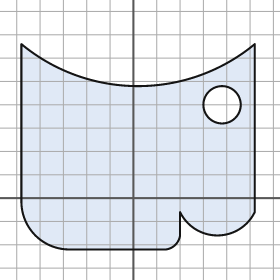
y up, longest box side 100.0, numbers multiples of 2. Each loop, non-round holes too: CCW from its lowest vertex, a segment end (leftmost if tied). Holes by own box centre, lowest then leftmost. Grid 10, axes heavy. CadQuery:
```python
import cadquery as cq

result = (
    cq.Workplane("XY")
    .moveTo(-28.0, -22.0)
    .lineTo(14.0, -22.0)
    .threePointArc((18.0, -20.0), (20.0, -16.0))
    .lineTo(20.0, -6.0)
    .threePointArc((36.0, -16.0), (52.0, -6.0))
    .lineTo(52.0, 66.0)
    .threePointArc((2.0, 48.0), (-48.0, 66.0))
    .lineTo(-48.0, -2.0)
    .threePointArc((-42.0, -16.0), (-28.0, -22.0))
    .close()
    .moveTo(38.0, 40.0)
    .circle(8.0)
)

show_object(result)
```